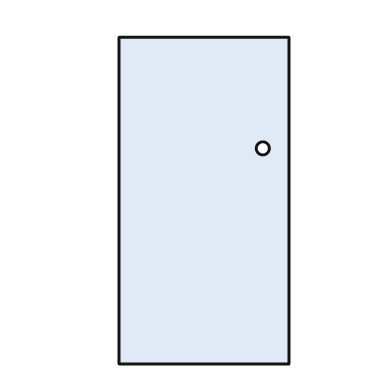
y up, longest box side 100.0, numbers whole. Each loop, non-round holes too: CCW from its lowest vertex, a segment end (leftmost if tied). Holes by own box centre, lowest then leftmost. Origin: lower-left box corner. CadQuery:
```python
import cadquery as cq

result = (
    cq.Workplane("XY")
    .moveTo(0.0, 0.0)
    .lineTo(52.0, 0.0)
    .lineTo(52.0, 100.0)
    .lineTo(0.0, 100.0)
    .close()
    .moveTo(44.0, 66.0)
    .circle(2.0)
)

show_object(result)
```